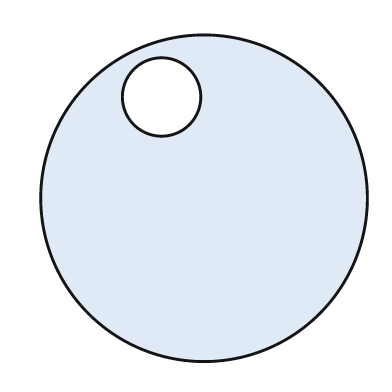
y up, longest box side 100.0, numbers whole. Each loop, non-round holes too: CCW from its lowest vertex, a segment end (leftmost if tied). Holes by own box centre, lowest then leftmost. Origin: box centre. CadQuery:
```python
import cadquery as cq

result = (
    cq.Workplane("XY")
    .moveTo(0.0, 0.0)
    .circle(50.0)
    .moveTo(-13.0, 31.0)
    .circle(12.0)
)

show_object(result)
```